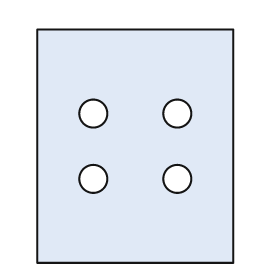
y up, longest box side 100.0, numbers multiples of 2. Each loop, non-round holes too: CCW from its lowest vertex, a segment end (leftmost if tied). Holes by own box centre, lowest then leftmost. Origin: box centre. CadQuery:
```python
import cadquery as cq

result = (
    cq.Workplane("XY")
    .moveTo(-42.0, -50.0)
    .lineTo(42.0, -50.0)
    .lineTo(42.0, 50.0)
    .lineTo(-42.0, 50.0)
    .close()
    .moveTo(-18.0, -14.0)
    .circle(6.0)
    .moveTo(18.0, -14.0)
    .circle(6.0)
    .moveTo(-18.0, 14.0)
    .circle(6.0)
    .moveTo(18.0, 14.0)
    .circle(6.0)
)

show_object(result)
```